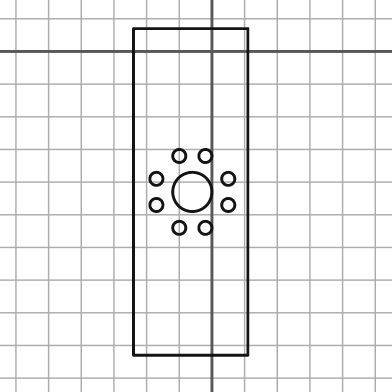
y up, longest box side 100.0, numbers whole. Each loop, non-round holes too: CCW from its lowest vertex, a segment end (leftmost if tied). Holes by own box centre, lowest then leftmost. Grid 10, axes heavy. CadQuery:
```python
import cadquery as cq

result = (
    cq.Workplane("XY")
    .moveTo(-24.0, -93.0)
    .lineTo(11.0, -93.0)
    .lineTo(11.0, 7.0)
    .lineTo(-24.0, 7.0)
    .close()
    .moveTo(-10.0, -54.0)
    .circle(2.0)
    .moveTo(-2.0, -54.0)
    .circle(2.0)
    .moveTo(-17.0, -47.0)
    .circle(2.0)
    .moveTo(5.0, -47.0)
    .circle(2.0)
    .moveTo(-6.0, -43.0)
    .circle(6.0)
    .moveTo(-17.0, -39.0)
    .circle(2.0)
    .moveTo(5.0, -39.0)
    .circle(2.0)
    .moveTo(-10.0, -32.0)
    .circle(2.0)
    .moveTo(-2.0, -32.0)
    .circle(2.0)
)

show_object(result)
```